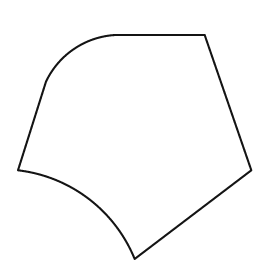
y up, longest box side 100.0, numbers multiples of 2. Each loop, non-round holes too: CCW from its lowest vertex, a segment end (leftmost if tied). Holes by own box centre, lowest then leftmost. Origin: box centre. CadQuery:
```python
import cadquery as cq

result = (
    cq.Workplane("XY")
    .moveTo(0.0, -48.0)
    .lineTo(50.0, -10.0)
    .lineTo(30.0, 48.0)
    .lineTo(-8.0, 48.0)
    .threePointArc((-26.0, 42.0), (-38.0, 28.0))
    .lineTo(-50.0, -10.0)
    .threePointArc((-20.0, -22.0), (0.0, -48.0))
    .close()
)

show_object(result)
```